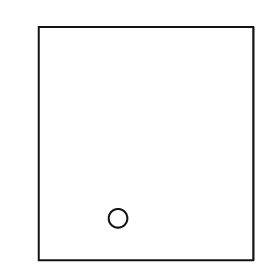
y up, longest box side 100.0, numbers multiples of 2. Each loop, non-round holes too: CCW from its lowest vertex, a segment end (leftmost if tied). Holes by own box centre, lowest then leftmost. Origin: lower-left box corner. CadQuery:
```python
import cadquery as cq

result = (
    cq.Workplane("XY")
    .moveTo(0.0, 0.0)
    .lineTo(92.0, 0.0)
    .lineTo(92.0, 100.0)
    .lineTo(0.0, 100.0)
    .close()
    .moveTo(34.0, 18.0)
    .circle(4.0)
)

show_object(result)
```